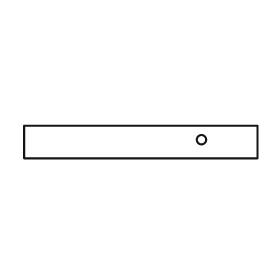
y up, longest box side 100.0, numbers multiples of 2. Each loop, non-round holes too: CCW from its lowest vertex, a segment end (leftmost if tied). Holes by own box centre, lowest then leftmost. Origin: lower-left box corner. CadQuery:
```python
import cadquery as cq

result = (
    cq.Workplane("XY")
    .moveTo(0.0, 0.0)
    .lineTo(100.0, 0.0)
    .lineTo(100.0, 14.0)
    .lineTo(0.0, 14.0)
    .close()
    .moveTo(76.0, 8.0)
    .circle(2.0)
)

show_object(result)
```